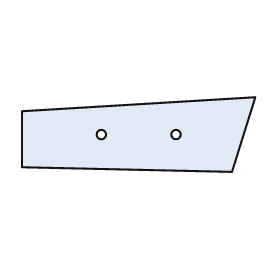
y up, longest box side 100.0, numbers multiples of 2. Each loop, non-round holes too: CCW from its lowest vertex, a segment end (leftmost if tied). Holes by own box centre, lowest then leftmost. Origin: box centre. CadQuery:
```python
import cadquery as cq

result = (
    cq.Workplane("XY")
    .moveTo(40.0, -16.0)
    .lineTo(50.0, 16.0)
    .lineTo(-50.0, 10.0)
    .lineTo(-50.0, -14.0)
    .close()
    .moveTo(-16.0, 0.0)
    .circle(2.0)
    .moveTo(16.0, 0.0)
    .circle(2.0)
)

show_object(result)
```